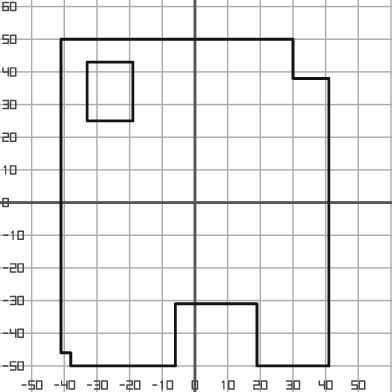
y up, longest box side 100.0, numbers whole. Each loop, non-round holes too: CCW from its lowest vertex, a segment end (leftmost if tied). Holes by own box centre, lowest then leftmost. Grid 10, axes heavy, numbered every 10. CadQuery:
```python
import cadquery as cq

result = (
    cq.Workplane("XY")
    .moveTo(-38.0, -50.0)
    .lineTo(-6.0, -50.0)
    .lineTo(-6.0, -31.0)
    .lineTo(19.0, -31.0)
    .lineTo(19.0, -50.0)
    .lineTo(41.0, -50.0)
    .lineTo(41.0, 38.0)
    .lineTo(30.0, 38.0)
    .lineTo(30.0, 50.0)
    .lineTo(-41.0, 50.0)
    .lineTo(-41.0, -46.0)
    .lineTo(-38.0, -46.0)
    .close()
    .moveTo(-33.0, 25.0)
    .lineTo(-19.0, 25.0)
    .lineTo(-19.0, 43.0)
    .lineTo(-33.0, 43.0)
    .close()
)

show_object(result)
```